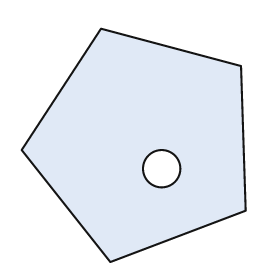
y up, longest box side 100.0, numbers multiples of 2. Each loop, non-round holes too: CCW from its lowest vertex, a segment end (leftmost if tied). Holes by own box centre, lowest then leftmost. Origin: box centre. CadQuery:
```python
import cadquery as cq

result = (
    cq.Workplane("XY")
    .moveTo(-10.0, -50.0)
    .lineTo(48.0, -28.0)
    .lineTo(46.0, 34.0)
    .lineTo(-14.0, 50.0)
    .lineTo(-48.0, -2.0)
    .close()
    .moveTo(12.0, -10.0)
    .circle(8.0)
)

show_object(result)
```